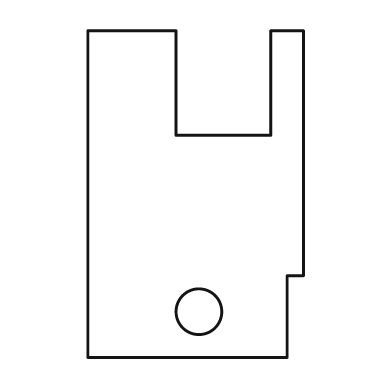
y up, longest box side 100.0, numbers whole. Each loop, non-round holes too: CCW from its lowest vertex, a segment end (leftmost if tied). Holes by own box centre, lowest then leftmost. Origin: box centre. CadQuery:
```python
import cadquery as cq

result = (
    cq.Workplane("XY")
    .moveTo(-33.0, -50.0)
    .lineTo(28.0, -50.0)
    .lineTo(28.0, -25.0)
    .lineTo(33.0, -25.0)
    .lineTo(33.0, 50.0)
    .lineTo(23.0, 50.0)
    .lineTo(23.0, 18.0)
    .lineTo(-6.0, 18.0)
    .lineTo(-6.0, 50.0)
    .lineTo(-33.0, 50.0)
    .close()
    .moveTo(1.0, -36.0)
    .circle(7.0)
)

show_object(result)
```